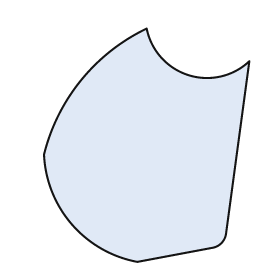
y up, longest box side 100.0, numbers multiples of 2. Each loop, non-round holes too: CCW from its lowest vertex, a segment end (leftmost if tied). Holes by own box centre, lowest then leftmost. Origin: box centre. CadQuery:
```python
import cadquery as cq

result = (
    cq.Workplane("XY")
    .moveTo(-4.0, -50.0)
    .lineTo(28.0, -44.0)
    .threePointArc((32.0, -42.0), (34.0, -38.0))
    .lineTo(44.0, 36.0)
    .threePointArc((18.0, 30.0), (0.0, 50.0))
    .threePointArc((-28.0, 28.0), (-44.0, -4.0))
    .threePointArc((-32.0, -34.0), (-4.0, -50.0))
    .close()
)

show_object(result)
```